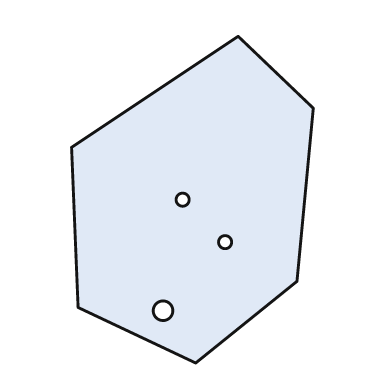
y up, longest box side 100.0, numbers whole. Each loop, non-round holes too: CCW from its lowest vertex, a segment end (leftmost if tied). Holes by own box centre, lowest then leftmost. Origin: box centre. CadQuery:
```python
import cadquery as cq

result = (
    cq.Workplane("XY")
    .moveTo(1.0, -50.0)
    .lineTo(32.0, -25.0)
    .lineTo(37.0, 28.0)
    .lineTo(14.0, 50.0)
    .lineTo(-37.0, 16.0)
    .lineTo(-35.0, -33.0)
    .close()
    .moveTo(-9.0, -34.0)
    .circle(3.0)
    .moveTo(10.0, -13.0)
    .circle(2.0)
    .moveTo(-3.0, 0.0)
    .circle(2.0)
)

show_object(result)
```